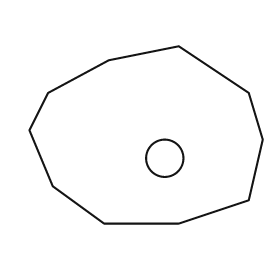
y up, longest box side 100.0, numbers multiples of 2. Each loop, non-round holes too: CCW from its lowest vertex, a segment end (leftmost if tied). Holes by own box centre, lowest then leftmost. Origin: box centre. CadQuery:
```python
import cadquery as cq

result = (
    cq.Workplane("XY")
    .moveTo(-18.0, -38.0)
    .lineTo(14.0, -38.0)
    .lineTo(44.0, -28.0)
    .lineTo(50.0, -2.0)
    .lineTo(44.0, 18.0)
    .lineTo(14.0, 38.0)
    .lineTo(-16.0, 32.0)
    .lineTo(-42.0, 18.0)
    .lineTo(-50.0, 2.0)
    .lineTo(-40.0, -22.0)
    .close()
    .moveTo(8.0, -10.0)
    .circle(8.0)
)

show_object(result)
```